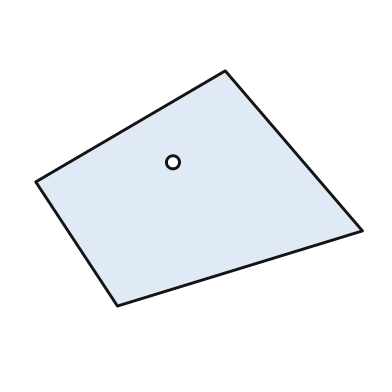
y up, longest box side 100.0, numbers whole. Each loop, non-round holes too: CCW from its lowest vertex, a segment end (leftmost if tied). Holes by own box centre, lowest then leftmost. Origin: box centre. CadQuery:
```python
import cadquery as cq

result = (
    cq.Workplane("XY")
    .moveTo(-25.0, -36.0)
    .lineTo(50.0, -13.0)
    .lineTo(8.0, 36.0)
    .lineTo(-50.0, 2.0)
    .close()
    .moveTo(-8.0, 8.0)
    .circle(2.0)
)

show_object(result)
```